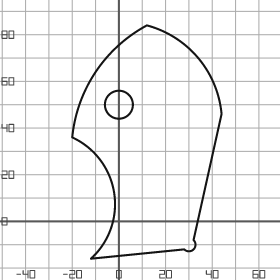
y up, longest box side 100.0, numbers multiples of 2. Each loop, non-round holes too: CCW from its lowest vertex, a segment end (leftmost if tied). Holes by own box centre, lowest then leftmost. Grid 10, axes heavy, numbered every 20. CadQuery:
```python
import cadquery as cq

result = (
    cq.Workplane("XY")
    .moveTo(-12.0, -16.0)
    .lineTo(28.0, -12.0)
    .threePointArc((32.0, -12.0), (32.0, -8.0))
    .lineTo(44.0, 46.0)
    .threePointArc((34.0, 70.0), (12.0, 84.0))
    .threePointArc((-10.0, 64.0), (-20.0, 36.0))
    .threePointArc((-2.0, 12.0), (-12.0, -16.0))
    .close()
    .moveTo(0.0, 50.0)
    .circle(6.0)
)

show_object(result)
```